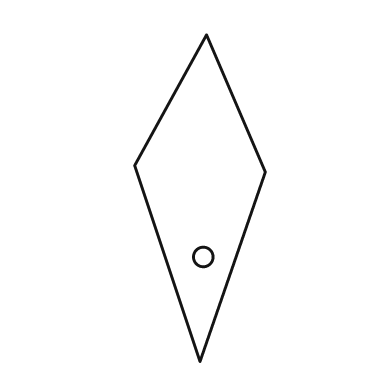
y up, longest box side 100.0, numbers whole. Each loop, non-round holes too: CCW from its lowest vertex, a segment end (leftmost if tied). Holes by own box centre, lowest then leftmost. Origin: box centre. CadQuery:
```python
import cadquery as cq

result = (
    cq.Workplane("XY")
    .moveTo(0.0, -50.0)
    .lineTo(20.0, 8.0)
    .lineTo(2.0, 50.0)
    .lineTo(-20.0, 10.0)
    .close()
    .moveTo(1.0, -18.0)
    .circle(3.0)
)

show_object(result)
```